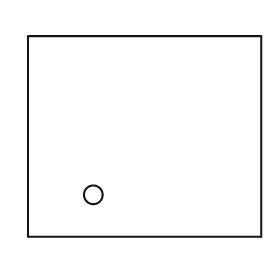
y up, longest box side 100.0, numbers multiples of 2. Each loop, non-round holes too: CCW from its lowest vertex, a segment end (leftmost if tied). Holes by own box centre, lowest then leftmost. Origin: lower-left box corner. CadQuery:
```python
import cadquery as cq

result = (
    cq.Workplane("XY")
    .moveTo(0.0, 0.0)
    .lineTo(100.0, 0.0)
    .lineTo(100.0, 86.0)
    .lineTo(0.0, 86.0)
    .close()
    .moveTo(28.0, 18.0)
    .circle(4.0)
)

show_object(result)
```